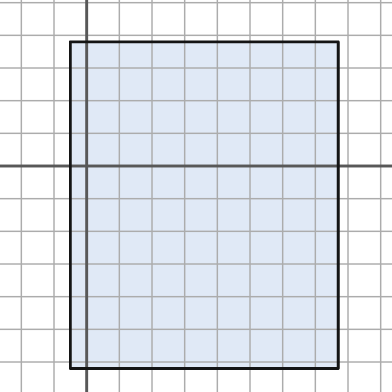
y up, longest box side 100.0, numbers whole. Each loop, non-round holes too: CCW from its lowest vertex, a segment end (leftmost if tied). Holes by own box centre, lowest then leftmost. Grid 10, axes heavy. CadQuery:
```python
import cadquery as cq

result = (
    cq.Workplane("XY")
    .moveTo(-5.0, -62.0)
    .lineTo(77.0, -62.0)
    .lineTo(77.0, 38.0)
    .lineTo(-5.0, 38.0)
    .close()
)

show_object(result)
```